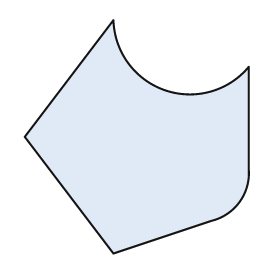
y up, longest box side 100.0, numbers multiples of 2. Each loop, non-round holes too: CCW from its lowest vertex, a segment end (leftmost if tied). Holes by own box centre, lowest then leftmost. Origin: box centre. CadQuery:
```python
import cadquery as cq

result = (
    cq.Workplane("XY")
    .moveTo(-10.0, -50.0)
    .lineTo(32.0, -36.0)
    .threePointArc((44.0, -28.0), (48.0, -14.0))
    .lineTo(48.0, 30.0)
    .threePointArc((12.0, 20.0), (-10.0, 50.0))
    .lineTo(-48.0, 0.0)
    .close()
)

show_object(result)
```